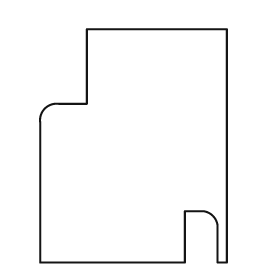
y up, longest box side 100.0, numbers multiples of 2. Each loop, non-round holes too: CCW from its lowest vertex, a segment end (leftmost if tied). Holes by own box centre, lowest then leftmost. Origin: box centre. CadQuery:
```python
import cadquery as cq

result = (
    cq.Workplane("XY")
    .moveTo(-40.0, -50.0)
    .lineTo(22.0, -50.0)
    .lineTo(22.0, -28.0)
    .lineTo(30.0, -28.0)
    .threePointArc((34.0, -30.0), (36.0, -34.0))
    .lineTo(36.0, -50.0)
    .lineTo(40.0, -50.0)
    .lineTo(40.0, 50.0)
    .lineTo(-20.0, 50.0)
    .lineTo(-20.0, 18.0)
    .lineTo(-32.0, 18.0)
    .threePointArc((-38.0, 16.0), (-40.0, 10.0))
    .close()
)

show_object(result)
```